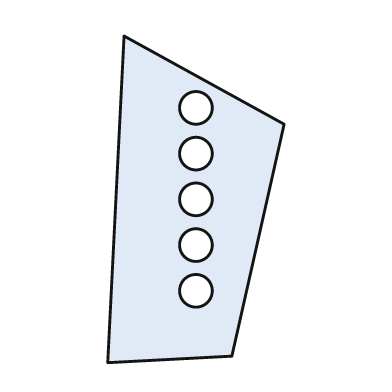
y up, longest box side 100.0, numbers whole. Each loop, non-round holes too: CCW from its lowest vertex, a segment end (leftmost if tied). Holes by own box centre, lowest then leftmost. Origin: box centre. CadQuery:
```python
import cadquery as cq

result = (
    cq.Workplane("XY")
    .moveTo(-27.0, -50.0)
    .lineTo(11.0, -48.0)
    .lineTo(27.0, 23.0)
    .lineTo(-22.0, 50.0)
    .close()
    .moveTo(0.0, -28.0)
    .circle(5.0)
    .moveTo(0.0, -14.0)
    .circle(5.0)
    .moveTo(0.0, 0.0)
    .circle(5.0)
    .moveTo(0.0, 14.0)
    .circle(5.0)
    .moveTo(0.0, 28.0)
    .circle(5.0)
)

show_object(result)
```